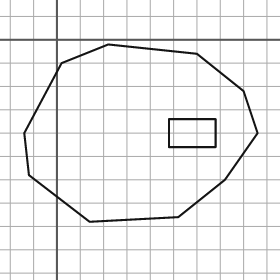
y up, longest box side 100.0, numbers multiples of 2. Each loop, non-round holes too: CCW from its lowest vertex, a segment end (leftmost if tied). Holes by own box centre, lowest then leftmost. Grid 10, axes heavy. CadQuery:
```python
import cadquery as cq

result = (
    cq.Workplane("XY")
    .moveTo(14.0, -78.0)
    .lineTo(52.0, -76.0)
    .lineTo(72.0, -60.0)
    .lineTo(86.0, -40.0)
    .lineTo(80.0, -22.0)
    .lineTo(60.0, -6.0)
    .lineTo(22.0, -2.0)
    .lineTo(2.0, -10.0)
    .lineTo(-14.0, -40.0)
    .lineTo(-12.0, -58.0)
    .close()
    .moveTo(48.0, -46.0)
    .lineTo(68.0, -46.0)
    .lineTo(68.0, -34.0)
    .lineTo(48.0, -34.0)
    .close()
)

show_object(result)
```